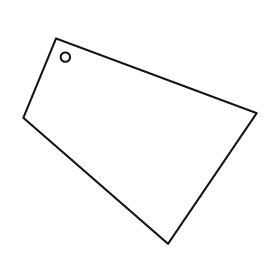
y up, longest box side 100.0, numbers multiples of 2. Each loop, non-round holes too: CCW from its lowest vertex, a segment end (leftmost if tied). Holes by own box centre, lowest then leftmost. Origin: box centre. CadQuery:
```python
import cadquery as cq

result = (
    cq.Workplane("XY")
    .moveTo(12.0, -44.0)
    .lineTo(50.0, 12.0)
    .lineTo(-36.0, 44.0)
    .lineTo(-50.0, 10.0)
    .close()
    .moveTo(-32.0, 36.0)
    .circle(2.0)
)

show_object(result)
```